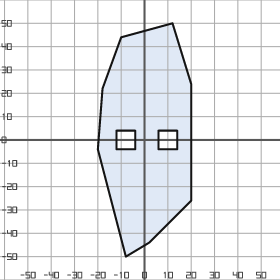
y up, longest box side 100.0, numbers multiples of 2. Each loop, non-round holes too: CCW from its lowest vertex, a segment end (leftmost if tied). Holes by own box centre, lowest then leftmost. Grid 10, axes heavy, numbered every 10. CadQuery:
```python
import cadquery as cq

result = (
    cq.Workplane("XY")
    .moveTo(-8.0, -50.0)
    .lineTo(2.0, -44.0)
    .lineTo(20.0, -26.0)
    .lineTo(20.0, 24.0)
    .lineTo(12.0, 50.0)
    .lineTo(-10.0, 44.0)
    .lineTo(-18.0, 22.0)
    .lineTo(-20.0, -4.0)
    .close()
    .moveTo(-12.0, -4.0)
    .lineTo(-4.0, -4.0)
    .lineTo(-4.0, 4.0)
    .lineTo(-12.0, 4.0)
    .close()
    .moveTo(6.0, -4.0)
    .lineTo(14.0, -4.0)
    .lineTo(14.0, 4.0)
    .lineTo(6.0, 4.0)
    .close()
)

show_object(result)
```